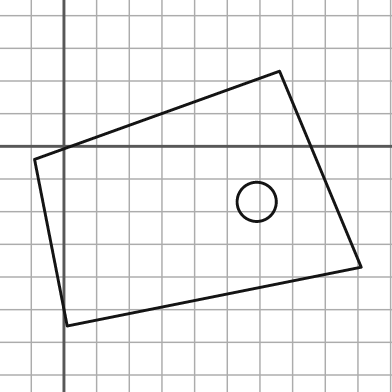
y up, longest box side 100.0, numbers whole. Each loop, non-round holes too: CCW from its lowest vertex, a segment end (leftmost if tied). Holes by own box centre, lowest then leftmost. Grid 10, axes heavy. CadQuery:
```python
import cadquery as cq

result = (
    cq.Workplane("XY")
    .moveTo(1.0, -55.0)
    .lineTo(91.0, -37.0)
    .lineTo(66.0, 23.0)
    .lineTo(-9.0, -4.0)
    .close()
    .moveTo(59.0, -17.0)
    .circle(6.0)
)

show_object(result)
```